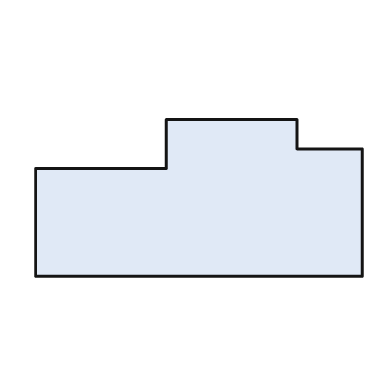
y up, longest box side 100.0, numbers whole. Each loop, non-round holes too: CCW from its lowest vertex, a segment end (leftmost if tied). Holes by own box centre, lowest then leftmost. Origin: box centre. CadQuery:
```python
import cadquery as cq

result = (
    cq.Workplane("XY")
    .moveTo(-50.0, -24.0)
    .lineTo(50.0, -24.0)
    .lineTo(50.0, 15.0)
    .lineTo(30.0, 15.0)
    .lineTo(30.0, 24.0)
    .lineTo(-10.0, 24.0)
    .lineTo(-10.0, 9.0)
    .lineTo(-50.0, 9.0)
    .close()
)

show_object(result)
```